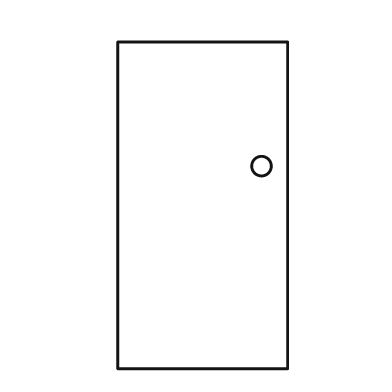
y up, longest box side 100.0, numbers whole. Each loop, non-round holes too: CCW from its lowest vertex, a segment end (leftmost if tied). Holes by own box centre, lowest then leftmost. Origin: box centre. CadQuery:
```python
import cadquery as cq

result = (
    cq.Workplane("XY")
    .moveTo(-26.0, -50.0)
    .lineTo(26.0, -50.0)
    .lineTo(26.0, 50.0)
    .lineTo(-26.0, 50.0)
    .close()
    .moveTo(18.0, 12.0)
    .circle(3.0)
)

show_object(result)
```